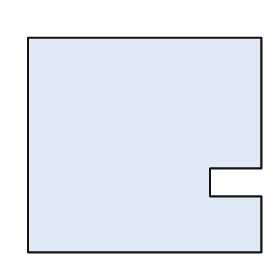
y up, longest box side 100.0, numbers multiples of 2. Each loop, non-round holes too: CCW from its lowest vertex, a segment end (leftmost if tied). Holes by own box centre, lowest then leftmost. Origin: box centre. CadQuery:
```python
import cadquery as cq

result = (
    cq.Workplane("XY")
    .moveTo(-50.0, -46.0)
    .lineTo(50.0, -46.0)
    .lineTo(50.0, -22.0)
    .lineTo(28.0, -22.0)
    .lineTo(28.0, -10.0)
    .lineTo(50.0, -10.0)
    .lineTo(50.0, 46.0)
    .lineTo(-50.0, 46.0)
    .close()
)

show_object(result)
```